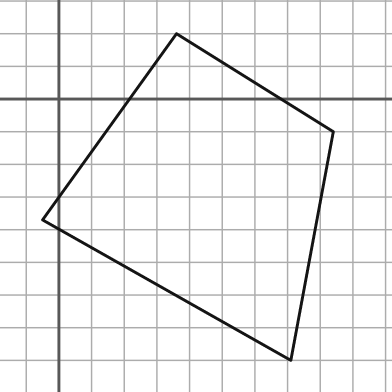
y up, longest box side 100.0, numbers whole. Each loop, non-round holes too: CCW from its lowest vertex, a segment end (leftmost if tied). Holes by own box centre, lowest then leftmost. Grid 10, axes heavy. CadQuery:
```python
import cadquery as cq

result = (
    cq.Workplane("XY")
    .moveTo(71.0, -80.0)
    .lineTo(84.0, -10.0)
    .lineTo(36.0, 20.0)
    .lineTo(-5.0, -37.0)
    .close()
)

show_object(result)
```